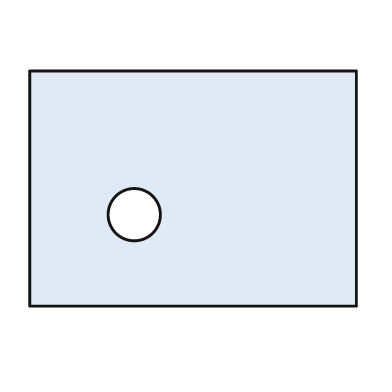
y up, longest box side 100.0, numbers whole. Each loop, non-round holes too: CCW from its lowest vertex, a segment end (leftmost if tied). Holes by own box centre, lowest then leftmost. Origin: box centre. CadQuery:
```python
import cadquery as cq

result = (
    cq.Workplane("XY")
    .moveTo(-50.0, -36.0)
    .lineTo(50.0, -36.0)
    .lineTo(50.0, 36.0)
    .lineTo(-50.0, 36.0)
    .close()
    .moveTo(-18.0, -8.0)
    .circle(8.0)
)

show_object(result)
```